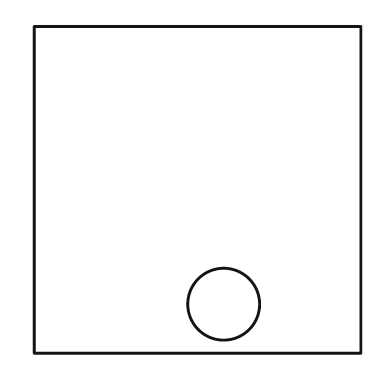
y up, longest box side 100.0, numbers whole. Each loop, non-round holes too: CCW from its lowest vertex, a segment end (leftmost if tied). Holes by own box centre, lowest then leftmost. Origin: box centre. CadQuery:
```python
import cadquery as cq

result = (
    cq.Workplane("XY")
    .moveTo(-50.0, -50.0)
    .lineTo(50.0, -50.0)
    .lineTo(50.0, 50.0)
    .lineTo(-50.0, 50.0)
    .close()
    .moveTo(8.0, -35.0)
    .circle(11.0)
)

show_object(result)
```